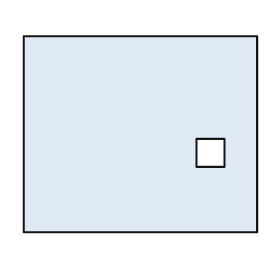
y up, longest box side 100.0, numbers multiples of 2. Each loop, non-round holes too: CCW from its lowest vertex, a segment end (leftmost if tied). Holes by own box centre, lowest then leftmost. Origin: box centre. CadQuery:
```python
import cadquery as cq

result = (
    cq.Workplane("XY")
    .moveTo(-50.0, -42.0)
    .lineTo(50.0, -42.0)
    .lineTo(50.0, 42.0)
    .lineTo(-50.0, 42.0)
    .close()
    .moveTo(24.0, -14.0)
    .lineTo(36.0, -14.0)
    .lineTo(36.0, -2.0)
    .lineTo(24.0, -2.0)
    .close()
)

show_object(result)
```